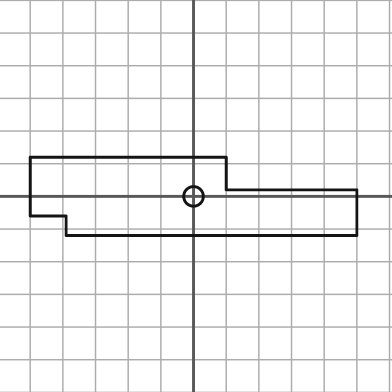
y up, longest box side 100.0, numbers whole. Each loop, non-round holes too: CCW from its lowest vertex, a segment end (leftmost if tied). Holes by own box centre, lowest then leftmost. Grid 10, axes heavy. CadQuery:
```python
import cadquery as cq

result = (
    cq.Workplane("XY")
    .moveTo(-39.0, -12.0)
    .lineTo(50.0, -12.0)
    .lineTo(50.0, 2.0)
    .lineTo(10.0, 2.0)
    .lineTo(10.0, 12.0)
    .lineTo(-50.0, 12.0)
    .lineTo(-50.0, -6.0)
    .lineTo(-39.0, -6.0)
    .close()
    .moveTo(0.0, 0.0)
    .circle(3.0)
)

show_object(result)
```